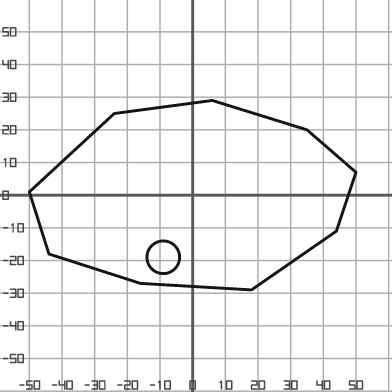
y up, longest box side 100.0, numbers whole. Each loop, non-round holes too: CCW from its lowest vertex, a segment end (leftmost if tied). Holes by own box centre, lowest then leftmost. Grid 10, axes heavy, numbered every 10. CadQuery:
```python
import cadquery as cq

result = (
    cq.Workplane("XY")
    .moveTo(18.0, -29.0)
    .lineTo(44.0, -11.0)
    .lineTo(50.0, 7.0)
    .lineTo(35.0, 20.0)
    .lineTo(6.0, 29.0)
    .lineTo(-24.0, 25.0)
    .lineTo(-50.0, 1.0)
    .lineTo(-44.0, -18.0)
    .lineTo(-16.0, -27.0)
    .close()
    .moveTo(-9.0, -19.0)
    .circle(5.0)
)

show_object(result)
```